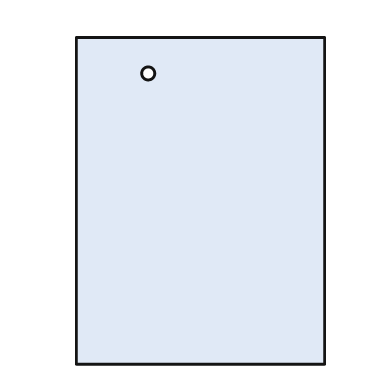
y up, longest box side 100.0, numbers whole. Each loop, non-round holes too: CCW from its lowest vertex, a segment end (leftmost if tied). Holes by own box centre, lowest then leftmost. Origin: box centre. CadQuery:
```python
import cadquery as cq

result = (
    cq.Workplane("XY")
    .moveTo(-38.0, -50.0)
    .lineTo(38.0, -50.0)
    .lineTo(38.0, 50.0)
    .lineTo(-38.0, 50.0)
    .close()
    .moveTo(-16.0, 39.0)
    .circle(2.0)
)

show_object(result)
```